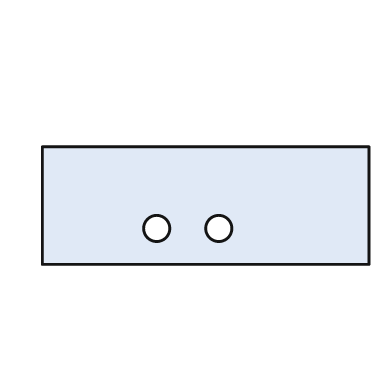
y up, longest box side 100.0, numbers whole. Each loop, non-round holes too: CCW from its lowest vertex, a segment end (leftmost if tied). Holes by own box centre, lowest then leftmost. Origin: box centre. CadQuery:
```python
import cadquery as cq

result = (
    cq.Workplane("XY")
    .moveTo(-50.0, -18.0)
    .lineTo(50.0, -18.0)
    .lineTo(50.0, 18.0)
    .lineTo(-50.0, 18.0)
    .close()
    .moveTo(-15.0, -7.0)
    .circle(4.0)
    .moveTo(4.0, -7.0)
    .circle(4.0)
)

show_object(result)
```